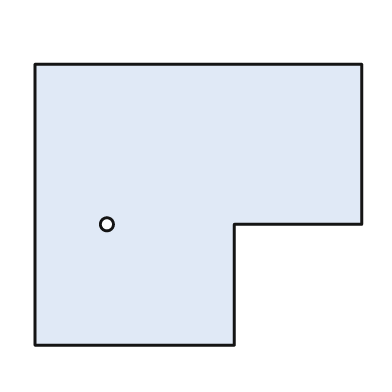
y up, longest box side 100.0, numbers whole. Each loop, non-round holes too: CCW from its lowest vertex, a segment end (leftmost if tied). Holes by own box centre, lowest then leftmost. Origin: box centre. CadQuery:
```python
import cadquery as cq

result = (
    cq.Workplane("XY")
    .moveTo(-50.0, -43.0)
    .lineTo(11.0, -43.0)
    .lineTo(11.0, -6.0)
    .lineTo(50.0, -6.0)
    .lineTo(50.0, 43.0)
    .lineTo(-50.0, 43.0)
    .close()
    .moveTo(-28.0, -6.0)
    .circle(2.0)
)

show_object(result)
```